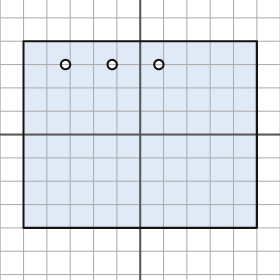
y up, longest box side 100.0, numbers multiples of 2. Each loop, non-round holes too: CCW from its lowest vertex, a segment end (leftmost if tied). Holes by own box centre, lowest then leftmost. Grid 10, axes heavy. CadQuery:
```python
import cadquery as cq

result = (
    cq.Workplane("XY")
    .moveTo(-50.0, -40.0)
    .lineTo(50.0, -40.0)
    .lineTo(50.0, 40.0)
    .lineTo(-50.0, 40.0)
    .close()
    .moveTo(-32.0, 30.0)
    .circle(2.0)
    .moveTo(-12.0, 30.0)
    .circle(2.0)
    .moveTo(8.0, 30.0)
    .circle(2.0)
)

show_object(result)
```